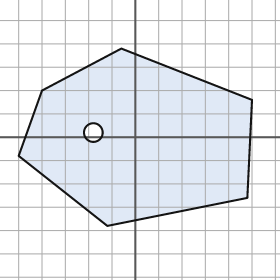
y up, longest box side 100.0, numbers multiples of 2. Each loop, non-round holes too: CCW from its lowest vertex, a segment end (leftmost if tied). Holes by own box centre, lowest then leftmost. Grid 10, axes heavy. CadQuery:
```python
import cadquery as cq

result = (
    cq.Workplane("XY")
    .moveTo(-12.0, -38.0)
    .lineTo(48.0, -26.0)
    .lineTo(50.0, 16.0)
    .lineTo(-6.0, 38.0)
    .lineTo(-40.0, 20.0)
    .lineTo(-50.0, -8.0)
    .close()
    .moveTo(-18.0, 2.0)
    .circle(4.0)
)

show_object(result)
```